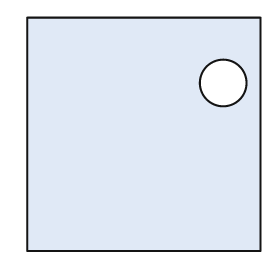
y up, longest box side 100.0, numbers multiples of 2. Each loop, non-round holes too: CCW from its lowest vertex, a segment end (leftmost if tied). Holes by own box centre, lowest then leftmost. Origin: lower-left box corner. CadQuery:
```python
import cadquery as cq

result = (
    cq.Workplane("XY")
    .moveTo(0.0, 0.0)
    .lineTo(100.0, 0.0)
    .lineTo(100.0, 100.0)
    .lineTo(0.0, 100.0)
    .close()
    .moveTo(84.0, 72.0)
    .circle(10.0)
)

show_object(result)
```